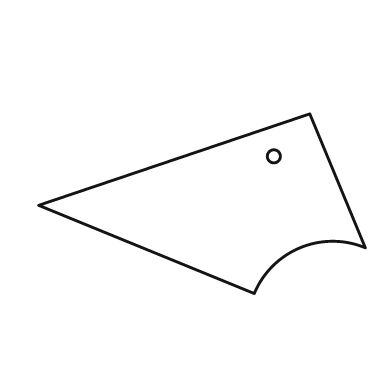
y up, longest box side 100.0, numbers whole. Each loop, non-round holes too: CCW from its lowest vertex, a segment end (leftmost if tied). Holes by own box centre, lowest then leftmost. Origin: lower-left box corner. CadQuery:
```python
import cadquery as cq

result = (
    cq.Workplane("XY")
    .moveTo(66.0, 0.0)
    .threePointArc((80.0, 14.0), (100.0, 14.0))
    .lineTo(83.0, 55.0)
    .lineTo(0.0, 27.0)
    .close()
    .moveTo(72.0, 42.0)
    .circle(2.0)
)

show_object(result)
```